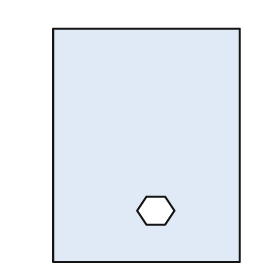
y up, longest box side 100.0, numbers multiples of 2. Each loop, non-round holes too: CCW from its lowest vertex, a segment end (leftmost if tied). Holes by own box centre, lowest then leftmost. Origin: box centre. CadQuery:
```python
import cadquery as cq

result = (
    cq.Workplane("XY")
    .moveTo(-40.0, -50.0)
    .lineTo(40.0, -50.0)
    .lineTo(40.0, 50.0)
    .lineTo(-40.0, 50.0)
    .close()
    .moveTo(0.0, -34.0)
    .lineTo(8.0, -34.0)
    .lineTo(12.0, -28.0)
    .lineTo(8.0, -22.0)
    .lineTo(0.0, -22.0)
    .lineTo(-4.0, -28.0)
    .close()
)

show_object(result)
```